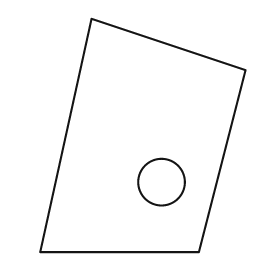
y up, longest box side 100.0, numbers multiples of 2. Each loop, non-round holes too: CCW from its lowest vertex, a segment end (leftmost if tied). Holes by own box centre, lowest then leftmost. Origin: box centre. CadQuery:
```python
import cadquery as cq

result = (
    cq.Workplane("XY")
    .moveTo(-44.0, -50.0)
    .lineTo(24.0, -50.0)
    .lineTo(44.0, 28.0)
    .lineTo(-22.0, 50.0)
    .close()
    .moveTo(8.0, -20.0)
    .circle(10.0)
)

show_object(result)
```